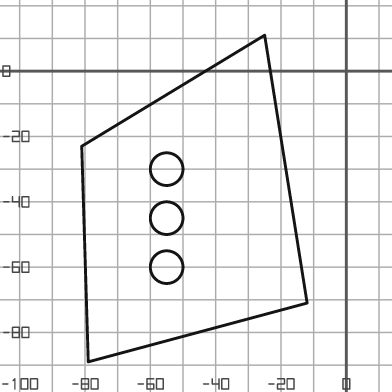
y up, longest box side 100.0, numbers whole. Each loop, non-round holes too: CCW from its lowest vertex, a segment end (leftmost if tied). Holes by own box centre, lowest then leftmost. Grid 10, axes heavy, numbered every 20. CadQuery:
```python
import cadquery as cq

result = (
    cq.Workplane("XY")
    .moveTo(-79.0, -89.0)
    .lineTo(-12.0, -71.0)
    .lineTo(-25.0, 11.0)
    .lineTo(-81.0, -23.0)
    .close()
    .moveTo(-55.0, -60.0)
    .circle(5.0)
    .moveTo(-55.0, -45.0)
    .circle(5.0)
    .moveTo(-55.0, -30.0)
    .circle(5.0)
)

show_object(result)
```